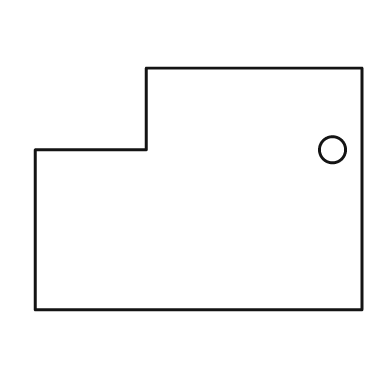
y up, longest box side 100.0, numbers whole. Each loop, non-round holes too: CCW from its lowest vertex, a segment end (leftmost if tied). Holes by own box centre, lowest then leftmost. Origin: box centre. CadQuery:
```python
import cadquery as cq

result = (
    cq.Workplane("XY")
    .moveTo(-50.0, -37.0)
    .lineTo(50.0, -37.0)
    .lineTo(50.0, 37.0)
    .lineTo(-16.0, 37.0)
    .lineTo(-16.0, 12.0)
    .lineTo(-50.0, 12.0)
    .close()
    .moveTo(41.0, 12.0)
    .circle(4.0)
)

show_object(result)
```